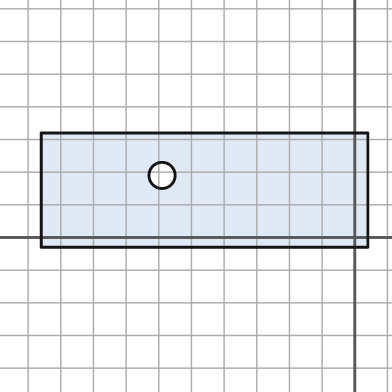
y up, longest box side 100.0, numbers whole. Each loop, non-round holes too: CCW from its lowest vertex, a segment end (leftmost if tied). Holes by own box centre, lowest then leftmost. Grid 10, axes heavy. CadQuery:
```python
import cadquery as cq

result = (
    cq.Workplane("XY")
    .moveTo(-96.0, -3.0)
    .lineTo(4.0, -3.0)
    .lineTo(4.0, 32.0)
    .lineTo(-96.0, 32.0)
    .close()
    .moveTo(-59.0, 19.0)
    .circle(4.0)
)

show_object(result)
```